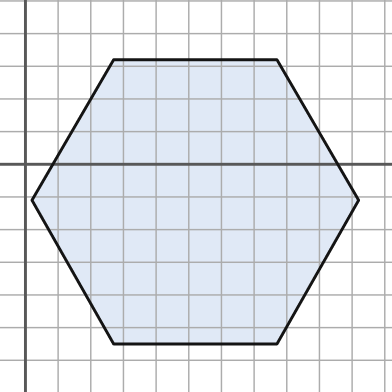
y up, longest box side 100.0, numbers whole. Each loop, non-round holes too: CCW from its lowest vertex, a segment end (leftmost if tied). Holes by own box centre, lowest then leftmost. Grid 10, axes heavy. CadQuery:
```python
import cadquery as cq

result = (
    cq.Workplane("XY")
    .moveTo(27.0, -55.0)
    .lineTo(77.0, -55.0)
    .lineTo(102.0, -11.0)
    .lineTo(77.0, 32.0)
    .lineTo(27.0, 32.0)
    .lineTo(2.0, -11.0)
    .close()
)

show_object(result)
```